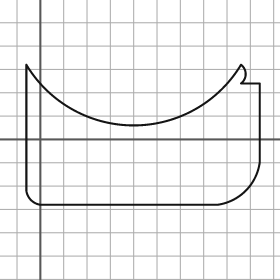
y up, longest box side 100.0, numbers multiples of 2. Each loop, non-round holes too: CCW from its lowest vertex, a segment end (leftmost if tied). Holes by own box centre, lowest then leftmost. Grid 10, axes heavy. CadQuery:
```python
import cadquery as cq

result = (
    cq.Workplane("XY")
    .moveTo(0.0, -28.0)
    .lineTo(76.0, -28.0)
    .threePointArc((88.0, -22.0), (94.0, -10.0))
    .lineTo(94.0, 24.0)
    .lineTo(86.0, 24.0)
    .threePointArc((88.0, 28.0), (86.0, 32.0))
    .threePointArc((40.0, 6.0), (-6.0, 32.0))
    .lineTo(-6.0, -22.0)
    .threePointArc((-4.0, -26.0), (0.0, -28.0))
    .close()
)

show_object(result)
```